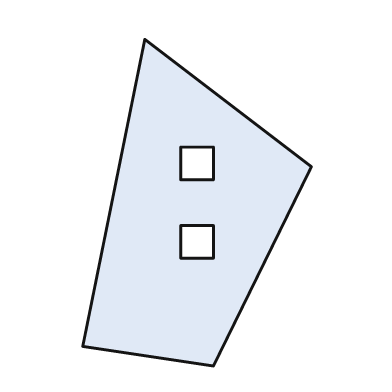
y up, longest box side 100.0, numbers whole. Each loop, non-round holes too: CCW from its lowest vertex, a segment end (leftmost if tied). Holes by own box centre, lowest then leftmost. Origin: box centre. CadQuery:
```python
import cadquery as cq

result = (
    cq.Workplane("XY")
    .moveTo(5.0, -50.0)
    .lineTo(35.0, 11.0)
    .lineTo(-16.0, 50.0)
    .lineTo(-35.0, -44.0)
    .close()
    .moveTo(-5.0, -17.0)
    .lineTo(5.0, -17.0)
    .lineTo(5.0, -7.0)
    .lineTo(-5.0, -7.0)
    .close()
    .moveTo(-5.0, 7.0)
    .lineTo(5.0, 7.0)
    .lineTo(5.0, 17.0)
    .lineTo(-5.0, 17.0)
    .close()
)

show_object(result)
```